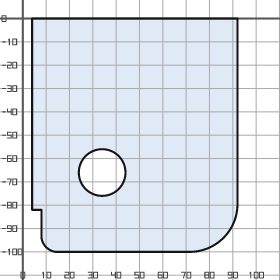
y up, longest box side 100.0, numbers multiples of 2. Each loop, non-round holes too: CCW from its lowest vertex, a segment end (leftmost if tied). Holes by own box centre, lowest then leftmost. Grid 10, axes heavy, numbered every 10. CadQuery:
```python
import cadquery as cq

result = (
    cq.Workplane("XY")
    .moveTo(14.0, -100.0)
    .lineTo(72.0, -100.0)
    .threePointArc((86.0, -94.0), (92.0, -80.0))
    .lineTo(92.0, 0.0)
    .lineTo(4.0, 0.0)
    .lineTo(4.0, -82.0)
    .lineTo(8.0, -82.0)
    .lineTo(8.0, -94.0)
    .threePointArc((10.0, -98.0), (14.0, -100.0))
    .close()
    .moveTo(34.0, -66.0)
    .circle(10.0)
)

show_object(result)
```